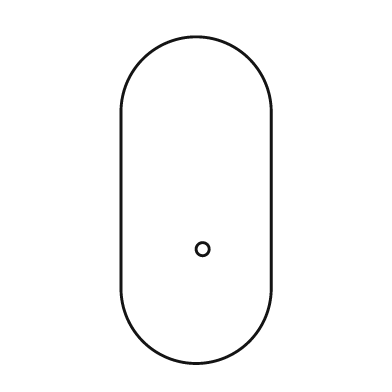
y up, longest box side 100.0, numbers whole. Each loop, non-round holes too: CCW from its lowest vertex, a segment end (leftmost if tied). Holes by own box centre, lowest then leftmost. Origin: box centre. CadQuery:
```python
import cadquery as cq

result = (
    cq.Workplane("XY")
    .moveTo(-23.0, -27.0)
    .threePointArc((0.0, -50.0), (23.0, -27.0))
    .lineTo(23.0, 27.0)
    .threePointArc((0.0, 50.0), (-23.0, 27.0))
    .close()
    .moveTo(2.0, -15.0)
    .circle(2.0)
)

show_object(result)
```